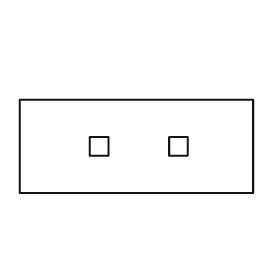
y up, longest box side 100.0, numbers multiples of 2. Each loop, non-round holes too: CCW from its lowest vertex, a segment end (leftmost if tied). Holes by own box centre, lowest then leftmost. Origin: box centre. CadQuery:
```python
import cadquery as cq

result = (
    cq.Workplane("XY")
    .moveTo(-50.0, -20.0)
    .lineTo(50.0, -20.0)
    .lineTo(50.0, 20.0)
    .lineTo(-50.0, 20.0)
    .close()
    .moveTo(-20.0, -4.0)
    .lineTo(-12.0, -4.0)
    .lineTo(-12.0, 4.0)
    .lineTo(-20.0, 4.0)
    .close()
    .moveTo(14.0, -4.0)
    .lineTo(22.0, -4.0)
    .lineTo(22.0, 4.0)
    .lineTo(14.0, 4.0)
    .close()
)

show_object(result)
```